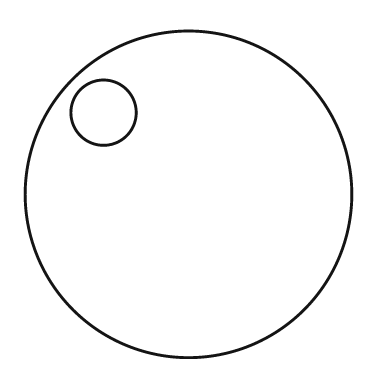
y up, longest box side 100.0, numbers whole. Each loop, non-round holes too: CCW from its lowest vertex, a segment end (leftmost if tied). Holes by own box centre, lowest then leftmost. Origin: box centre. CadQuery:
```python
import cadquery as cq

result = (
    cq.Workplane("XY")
    .moveTo(0.0, 0.0)
    .circle(50.0)
    .moveTo(-26.0, 25.0)
    .circle(10.0)
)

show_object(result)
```